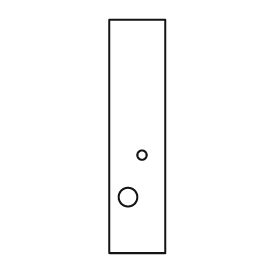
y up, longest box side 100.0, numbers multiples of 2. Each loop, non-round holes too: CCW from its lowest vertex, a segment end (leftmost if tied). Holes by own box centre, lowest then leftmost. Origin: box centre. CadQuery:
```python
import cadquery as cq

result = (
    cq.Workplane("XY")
    .moveTo(-12.0, -50.0)
    .lineTo(12.0, -50.0)
    .lineTo(12.0, 50.0)
    .lineTo(-12.0, 50.0)
    .close()
    .moveTo(-4.0, -26.0)
    .circle(4.0)
    .moveTo(2.0, -8.0)
    .circle(2.0)
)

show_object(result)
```